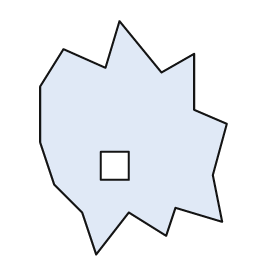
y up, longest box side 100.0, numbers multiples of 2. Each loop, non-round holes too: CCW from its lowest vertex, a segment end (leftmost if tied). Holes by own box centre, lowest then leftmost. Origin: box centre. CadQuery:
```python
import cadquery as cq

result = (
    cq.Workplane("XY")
    .moveTo(-16.0, -50.0)
    .lineTo(-2.0, -32.0)
    .lineTo(14.0, -42.0)
    .lineTo(18.0, -30.0)
    .lineTo(38.0, -36.0)
    .lineTo(34.0, -16.0)
    .lineTo(40.0, 6.0)
    .lineTo(26.0, 12.0)
    .lineTo(26.0, 36.0)
    .lineTo(12.0, 28.0)
    .lineTo(-6.0, 50.0)
    .lineTo(-12.0, 30.0)
    .lineTo(-30.0, 38.0)
    .lineTo(-40.0, 22.0)
    .lineTo(-40.0, -2.0)
    .lineTo(-34.0, -20.0)
    .lineTo(-22.0, -32.0)
    .close()
    .moveTo(-14.0, -18.0)
    .lineTo(-2.0, -18.0)
    .lineTo(-2.0, -6.0)
    .lineTo(-14.0, -6.0)
    .close()
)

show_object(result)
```